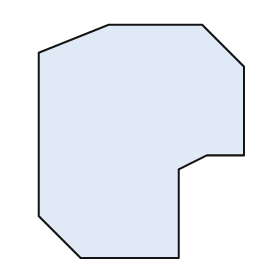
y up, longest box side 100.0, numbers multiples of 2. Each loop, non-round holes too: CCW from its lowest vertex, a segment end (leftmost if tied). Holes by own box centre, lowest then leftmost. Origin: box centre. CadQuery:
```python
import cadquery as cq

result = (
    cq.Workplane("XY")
    .moveTo(-26.0, -50.0)
    .lineTo(16.0, -50.0)
    .lineTo(16.0, -12.0)
    .lineTo(28.0, -6.0)
    .lineTo(44.0, -6.0)
    .lineTo(44.0, 32.0)
    .lineTo(26.0, 50.0)
    .lineTo(-14.0, 50.0)
    .lineTo(-44.0, 38.0)
    .lineTo(-44.0, -32.0)
    .close()
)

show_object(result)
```